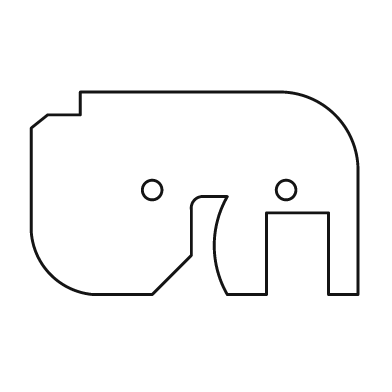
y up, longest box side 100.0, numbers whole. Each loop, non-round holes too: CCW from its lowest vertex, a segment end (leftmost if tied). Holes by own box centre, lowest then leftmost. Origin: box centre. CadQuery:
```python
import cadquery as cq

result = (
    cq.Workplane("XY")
    .moveTo(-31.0, -31.0)
    .lineTo(-13.0, -31.0)
    .lineTo(-1.0, -19.0)
    .lineTo(-1.0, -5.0)
    .threePointArc((0.0, -2.0), (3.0, -1.0))
    .lineTo(10.0, -1.0)
    .threePointArc((6.0, -16.0), (10.0, -31.0))
    .lineTo(22.0, -31.0)
    .lineTo(22.0, -6.0)
    .lineTo(41.0, -6.0)
    .lineTo(41.0, -31.0)
    .lineTo(50.0, -31.0)
    .lineTo(50.0, 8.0)
    .threePointArc((43.0, 24.0), (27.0, 31.0))
    .lineTo(-35.0, 31.0)
    .lineTo(-35.0, 24.0)
    .lineTo(-45.0, 24.0)
    .lineTo(-50.0, 20.0)
    .lineTo(-50.0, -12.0)
    .threePointArc((-44.0, -25.0), (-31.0, -31.0))
    .close()
    .moveTo(-13.0, 1.0)
    .circle(3.0)
    .moveTo(28.0, 1.0)
    .circle(3.0)
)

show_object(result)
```